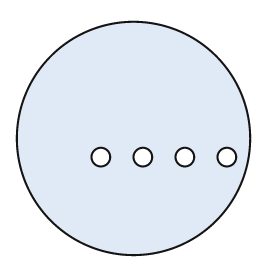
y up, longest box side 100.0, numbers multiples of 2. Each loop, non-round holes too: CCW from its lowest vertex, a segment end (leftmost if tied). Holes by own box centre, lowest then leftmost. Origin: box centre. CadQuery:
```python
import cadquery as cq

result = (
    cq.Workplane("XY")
    .moveTo(0.0, 0.0)
    .circle(50.0)
    .moveTo(-14.0, -8.0)
    .circle(4.0)
    .moveTo(4.0, -8.0)
    .circle(4.0)
    .moveTo(22.0, -8.0)
    .circle(4.0)
    .moveTo(40.0, -8.0)
    .circle(4.0)
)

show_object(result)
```